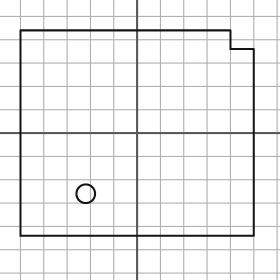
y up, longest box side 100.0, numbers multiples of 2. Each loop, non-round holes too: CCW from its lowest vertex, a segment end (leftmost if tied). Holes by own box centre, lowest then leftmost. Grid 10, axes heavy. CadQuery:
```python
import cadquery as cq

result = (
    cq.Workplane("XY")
    .moveTo(-50.0, -44.0)
    .lineTo(50.0, -44.0)
    .lineTo(50.0, 36.0)
    .lineTo(40.0, 36.0)
    .lineTo(40.0, 44.0)
    .lineTo(-50.0, 44.0)
    .close()
    .moveTo(-22.0, -26.0)
    .circle(4.0)
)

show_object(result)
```